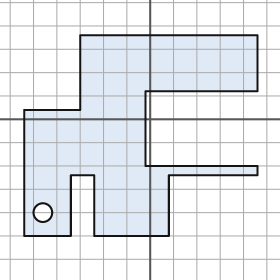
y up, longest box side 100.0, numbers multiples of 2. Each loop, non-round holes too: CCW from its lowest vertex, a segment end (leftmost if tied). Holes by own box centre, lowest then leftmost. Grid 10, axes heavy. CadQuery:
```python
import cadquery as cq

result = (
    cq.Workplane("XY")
    .moveTo(-54.0, -50.0)
    .lineTo(-34.0, -50.0)
    .lineTo(-34.0, -24.0)
    .lineTo(-24.0, -24.0)
    .lineTo(-24.0, -50.0)
    .lineTo(8.0, -50.0)
    .lineTo(8.0, -24.0)
    .lineTo(46.0, -24.0)
    .lineTo(46.0, -20.0)
    .lineTo(-2.0, -20.0)
    .lineTo(-2.0, 12.0)
    .lineTo(46.0, 12.0)
    .lineTo(46.0, 36.0)
    .lineTo(-30.0, 36.0)
    .lineTo(-30.0, 4.0)
    .lineTo(-54.0, 4.0)
    .close()
    .moveTo(-46.0, -40.0)
    .circle(4.0)
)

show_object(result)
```